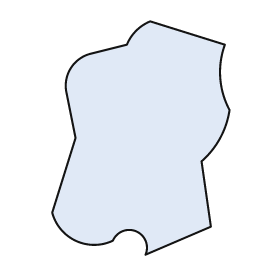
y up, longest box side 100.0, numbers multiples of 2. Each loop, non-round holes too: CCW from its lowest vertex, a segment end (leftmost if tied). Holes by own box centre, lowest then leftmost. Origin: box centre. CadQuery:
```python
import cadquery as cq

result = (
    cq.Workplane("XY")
    .moveTo(2.0, -50.0)
    .lineTo(30.0, -38.0)
    .lineTo(26.0, -10.0)
    .threePointArc((34.0, 0.0), (38.0, 12.0))
    .threePointArc((34.0, 26.0), (36.0, 40.0))
    .lineTo(4.0, 50.0)
    .threePointArc((-2.0, 46.0), (-6.0, 40.0))
    .lineTo(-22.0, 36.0)
    .threePointArc((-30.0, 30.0), (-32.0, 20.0))
    .lineTo(-28.0, 0.0)
    .lineTo(-38.0, -32.0)
    .threePointArc((-28.0, -44.0), (-12.0, -44.0))
    .threePointArc((-2.0, -40.0), (2.0, -50.0))
    .close()
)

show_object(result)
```